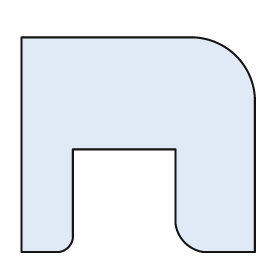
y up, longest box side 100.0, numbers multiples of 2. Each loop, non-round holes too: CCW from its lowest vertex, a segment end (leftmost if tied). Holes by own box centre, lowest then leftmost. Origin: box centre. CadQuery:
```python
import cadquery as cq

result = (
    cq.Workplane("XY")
    .moveTo(-50.0, -46.0)
    .lineTo(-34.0, -46.0)
    .threePointArc((-30.0, -44.0), (-28.0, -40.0))
    .lineTo(-28.0, -2.0)
    .lineTo(16.0, -2.0)
    .lineTo(16.0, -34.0)
    .threePointArc((20.0, -42.0), (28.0, -46.0))
    .lineTo(50.0, -46.0)
    .lineTo(50.0, 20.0)
    .threePointArc((42.0, 38.0), (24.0, 46.0))
    .lineTo(-50.0, 46.0)
    .close()
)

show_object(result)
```